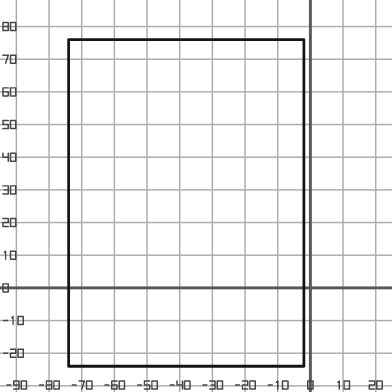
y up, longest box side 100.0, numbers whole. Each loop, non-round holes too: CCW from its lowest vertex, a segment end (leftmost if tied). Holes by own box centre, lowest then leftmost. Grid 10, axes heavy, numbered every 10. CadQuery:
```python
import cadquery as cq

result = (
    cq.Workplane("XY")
    .moveTo(-74.0, -24.0)
    .lineTo(-2.0, -24.0)
    .lineTo(-2.0, 76.0)
    .lineTo(-74.0, 76.0)
    .close()
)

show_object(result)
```